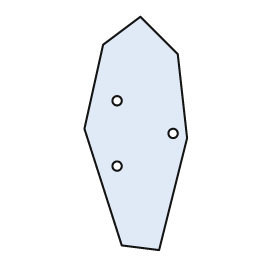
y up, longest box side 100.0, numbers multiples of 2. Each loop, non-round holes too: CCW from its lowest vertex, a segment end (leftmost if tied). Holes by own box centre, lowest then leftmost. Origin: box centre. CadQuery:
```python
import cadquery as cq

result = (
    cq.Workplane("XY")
    .moveTo(10.0, -50.0)
    .lineTo(22.0, -2.0)
    .lineTo(18.0, 34.0)
    .lineTo(2.0, 50.0)
    .lineTo(-14.0, 38.0)
    .lineTo(-22.0, 2.0)
    .lineTo(-6.0, -48.0)
    .close()
    .moveTo(-8.0, -14.0)
    .circle(2.0)
    .moveTo(16.0, 0.0)
    .circle(2.0)
    .moveTo(-8.0, 14.0)
    .circle(2.0)
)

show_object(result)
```